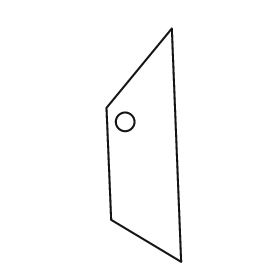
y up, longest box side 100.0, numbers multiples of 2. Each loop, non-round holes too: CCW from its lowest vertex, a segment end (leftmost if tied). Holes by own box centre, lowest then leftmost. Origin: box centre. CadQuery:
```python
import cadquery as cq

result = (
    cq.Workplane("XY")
    .moveTo(16.0, -50.0)
    .lineTo(12.0, 50.0)
    .lineTo(-16.0, 16.0)
    .lineTo(-14.0, -32.0)
    .close()
    .moveTo(-8.0, 10.0)
    .circle(4.0)
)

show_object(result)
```